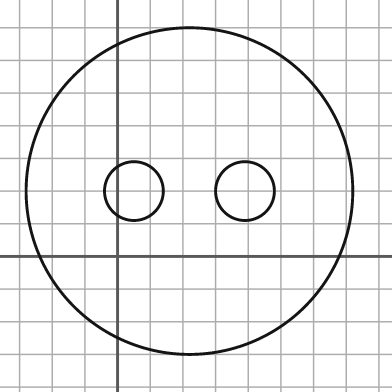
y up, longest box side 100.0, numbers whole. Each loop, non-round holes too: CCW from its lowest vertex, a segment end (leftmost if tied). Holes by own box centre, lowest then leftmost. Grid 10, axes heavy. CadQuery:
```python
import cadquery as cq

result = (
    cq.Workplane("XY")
    .moveTo(22.0, 20.0)
    .circle(50.0)
    .moveTo(5.0, 20.0)
    .circle(9.0)
    .moveTo(39.0, 20.0)
    .circle(9.0)
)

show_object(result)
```